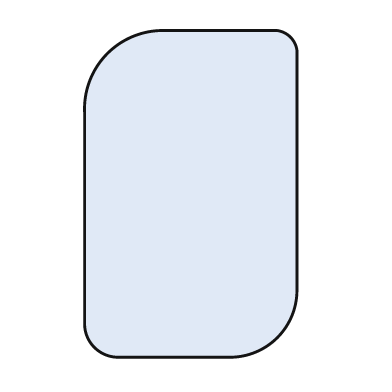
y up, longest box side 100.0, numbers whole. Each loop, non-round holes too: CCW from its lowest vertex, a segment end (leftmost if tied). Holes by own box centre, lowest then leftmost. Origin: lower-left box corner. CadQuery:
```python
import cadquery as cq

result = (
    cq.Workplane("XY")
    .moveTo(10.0, 0.0)
    .lineTo(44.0, 0.0)
    .threePointArc((59.0, 6.0), (65.0, 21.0))
    .lineTo(65.0, 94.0)
    .threePointArc((63.0, 98.0), (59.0, 100.0))
    .lineTo(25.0, 100.0)
    .threePointArc((7.0, 93.0), (0.0, 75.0))
    .lineTo(0.0, 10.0)
    .threePointArc((3.0, 3.0), (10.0, 0.0))
    .close()
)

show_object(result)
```